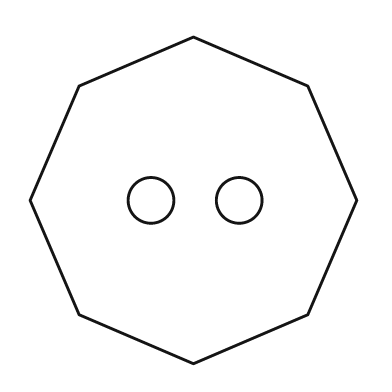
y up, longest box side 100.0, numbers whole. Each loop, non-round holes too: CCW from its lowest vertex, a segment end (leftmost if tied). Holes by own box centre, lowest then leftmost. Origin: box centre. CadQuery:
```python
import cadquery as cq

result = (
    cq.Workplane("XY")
    .moveTo(0.0, -50.0)
    .lineTo(35.0, -35.0)
    .lineTo(50.0, 0.0)
    .lineTo(35.0, 35.0)
    .lineTo(0.0, 50.0)
    .lineTo(-35.0, 35.0)
    .lineTo(-50.0, 0.0)
    .lineTo(-35.0, -35.0)
    .close()
    .moveTo(-13.0, 0.0)
    .circle(7.0)
    .moveTo(14.0, 0.0)
    .circle(7.0)
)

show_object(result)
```